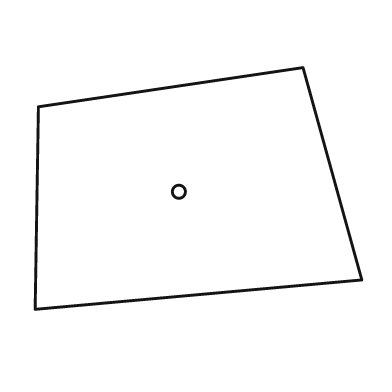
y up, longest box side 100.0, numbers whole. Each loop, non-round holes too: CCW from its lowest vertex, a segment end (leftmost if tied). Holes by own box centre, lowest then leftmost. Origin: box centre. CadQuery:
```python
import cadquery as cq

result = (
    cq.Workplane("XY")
    .moveTo(-50.0, -37.0)
    .lineTo(50.0, -28.0)
    .lineTo(32.0, 37.0)
    .lineTo(-49.0, 25.0)
    .close()
    .moveTo(-6.0, -1.0)
    .circle(2.0)
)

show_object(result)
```